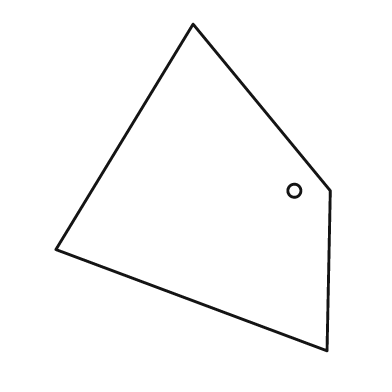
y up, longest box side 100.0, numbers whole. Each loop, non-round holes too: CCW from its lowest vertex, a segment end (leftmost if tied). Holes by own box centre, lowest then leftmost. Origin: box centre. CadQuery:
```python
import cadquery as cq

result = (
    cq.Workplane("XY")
    .moveTo(41.0, -50.0)
    .lineTo(42.0, -1.0)
    .lineTo(0.0, 50.0)
    .lineTo(-42.0, -19.0)
    .close()
    .moveTo(31.0, -1.0)
    .circle(2.0)
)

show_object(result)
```